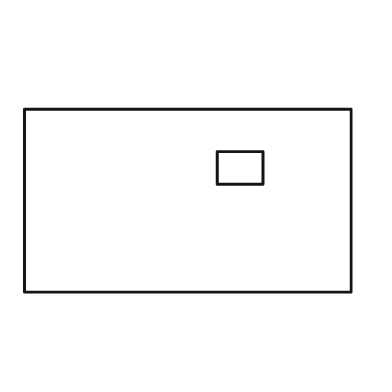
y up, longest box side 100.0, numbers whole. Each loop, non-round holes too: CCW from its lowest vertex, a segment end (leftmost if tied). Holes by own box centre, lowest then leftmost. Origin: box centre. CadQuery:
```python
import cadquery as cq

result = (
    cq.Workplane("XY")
    .moveTo(-50.0, -28.0)
    .lineTo(50.0, -28.0)
    .lineTo(50.0, 28.0)
    .lineTo(-50.0, 28.0)
    .close()
    .moveTo(9.0, 5.0)
    .lineTo(23.0, 5.0)
    .lineTo(23.0, 15.0)
    .lineTo(9.0, 15.0)
    .close()
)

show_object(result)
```